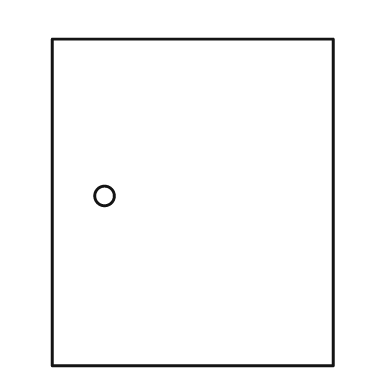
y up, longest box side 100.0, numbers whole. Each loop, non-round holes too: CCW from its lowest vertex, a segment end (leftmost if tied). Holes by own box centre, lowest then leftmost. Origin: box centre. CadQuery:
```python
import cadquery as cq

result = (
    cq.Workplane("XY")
    .moveTo(-43.0, -50.0)
    .lineTo(43.0, -50.0)
    .lineTo(43.0, 50.0)
    .lineTo(-43.0, 50.0)
    .close()
    .moveTo(-27.0, 2.0)
    .circle(3.0)
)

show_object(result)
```